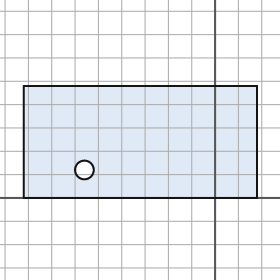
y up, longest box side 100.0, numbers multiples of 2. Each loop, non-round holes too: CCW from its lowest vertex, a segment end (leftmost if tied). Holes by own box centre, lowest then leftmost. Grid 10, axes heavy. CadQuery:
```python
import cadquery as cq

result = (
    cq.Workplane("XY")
    .moveTo(-82.0, 0.0)
    .lineTo(18.0, 0.0)
    .lineTo(18.0, 48.0)
    .lineTo(-82.0, 48.0)
    .close()
    .moveTo(-56.0, 12.0)
    .circle(4.0)
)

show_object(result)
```